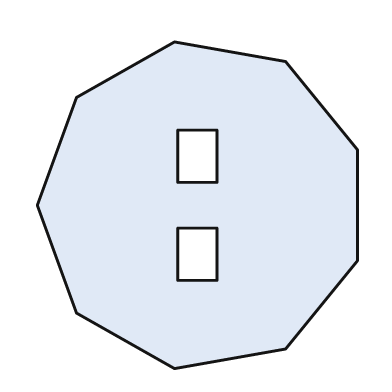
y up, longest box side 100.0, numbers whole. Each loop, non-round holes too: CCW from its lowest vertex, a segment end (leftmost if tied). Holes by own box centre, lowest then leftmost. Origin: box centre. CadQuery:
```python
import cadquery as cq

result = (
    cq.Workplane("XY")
    .moveTo(-7.0, -50.0)
    .lineTo(27.0, -44.0)
    .lineTo(49.0, -17.0)
    .lineTo(49.0, 17.0)
    .lineTo(27.0, 44.0)
    .lineTo(-7.0, 50.0)
    .lineTo(-37.0, 33.0)
    .lineTo(-49.0, 0.0)
    .lineTo(-37.0, -33.0)
    .close()
    .moveTo(-6.0, -23.0)
    .lineTo(6.0, -23.0)
    .lineTo(6.0, -7.0)
    .lineTo(-6.0, -7.0)
    .close()
    .moveTo(-6.0, 7.0)
    .lineTo(6.0, 7.0)
    .lineTo(6.0, 23.0)
    .lineTo(-6.0, 23.0)
    .close()
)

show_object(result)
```